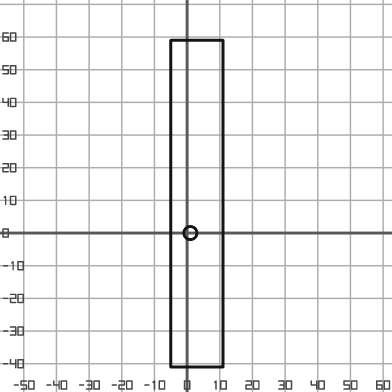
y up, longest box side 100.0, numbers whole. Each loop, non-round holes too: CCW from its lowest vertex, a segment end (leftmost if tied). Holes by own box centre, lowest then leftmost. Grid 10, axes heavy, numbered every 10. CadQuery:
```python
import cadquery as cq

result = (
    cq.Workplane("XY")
    .moveTo(-5.0, -41.0)
    .lineTo(11.0, -41.0)
    .lineTo(11.0, 59.0)
    .lineTo(-5.0, 59.0)
    .close()
    .moveTo(1.0, 0.0)
    .circle(2.0)
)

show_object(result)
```